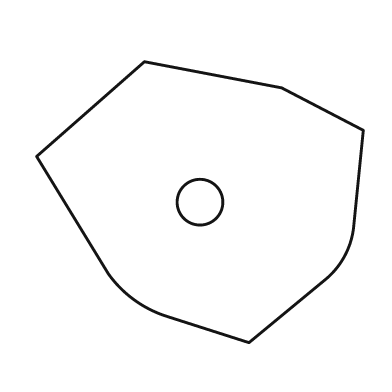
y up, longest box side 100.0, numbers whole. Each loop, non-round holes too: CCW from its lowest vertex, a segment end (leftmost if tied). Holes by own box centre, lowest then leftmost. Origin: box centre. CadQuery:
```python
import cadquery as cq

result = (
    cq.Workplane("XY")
    .moveTo(15.0, -43.0)
    .lineTo(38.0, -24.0)
    .threePointArc((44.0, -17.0), (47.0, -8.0))
    .lineTo(50.0, 22.0)
    .lineTo(25.0, 35.0)
    .lineTo(-17.0, 43.0)
    .lineTo(-50.0, 14.0)
    .lineTo(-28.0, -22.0)
    .threePointArc((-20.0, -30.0), (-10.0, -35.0))
    .close()
    .moveTo(0.0, 0.0)
    .circle(7.0)
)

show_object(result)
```